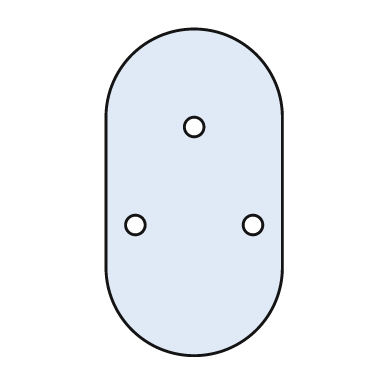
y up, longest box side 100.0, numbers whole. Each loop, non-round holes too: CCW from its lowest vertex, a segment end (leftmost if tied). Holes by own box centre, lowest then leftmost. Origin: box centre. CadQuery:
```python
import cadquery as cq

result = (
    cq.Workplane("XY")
    .moveTo(-27.0, -23.0)
    .threePointArc((0.0, -50.0), (27.0, -23.0))
    .lineTo(27.0, 23.0)
    .threePointArc((0.0, 50.0), (-27.0, 23.0))
    .close()
    .moveTo(-18.0, -10.0)
    .circle(3.0)
    .moveTo(18.0, -10.0)
    .circle(3.0)
    .moveTo(0.0, 20.0)
    .circle(3.0)
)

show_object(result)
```